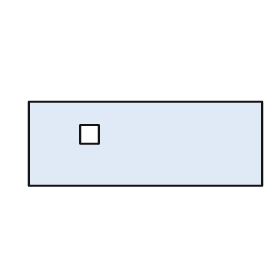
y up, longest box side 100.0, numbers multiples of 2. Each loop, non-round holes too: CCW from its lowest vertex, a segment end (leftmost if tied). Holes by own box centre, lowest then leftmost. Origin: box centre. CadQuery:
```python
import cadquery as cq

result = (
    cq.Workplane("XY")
    .moveTo(-50.0, -18.0)
    .lineTo(50.0, -18.0)
    .lineTo(50.0, 18.0)
    .lineTo(-50.0, 18.0)
    .close()
    .moveTo(-28.0, 0.0)
    .lineTo(-20.0, 0.0)
    .lineTo(-20.0, 8.0)
    .lineTo(-28.0, 8.0)
    .close()
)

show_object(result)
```